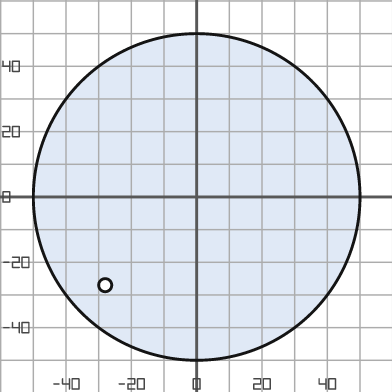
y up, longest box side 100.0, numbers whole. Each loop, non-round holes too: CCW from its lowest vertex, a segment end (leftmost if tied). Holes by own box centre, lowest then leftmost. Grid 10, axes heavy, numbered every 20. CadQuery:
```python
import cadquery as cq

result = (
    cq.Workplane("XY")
    .moveTo(0.0, 0.0)
    .circle(50.0)
    .moveTo(-28.0, -27.0)
    .circle(2.0)
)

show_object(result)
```